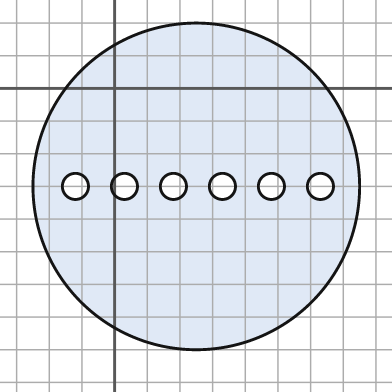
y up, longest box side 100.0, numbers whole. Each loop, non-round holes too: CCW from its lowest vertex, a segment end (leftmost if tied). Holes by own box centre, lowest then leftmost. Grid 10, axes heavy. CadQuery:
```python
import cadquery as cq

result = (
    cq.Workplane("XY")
    .moveTo(25.0, -30.0)
    .circle(50.0)
    .moveTo(-12.0, -30.0)
    .circle(4.0)
    .moveTo(3.0, -30.0)
    .circle(4.0)
    .moveTo(18.0, -30.0)
    .circle(4.0)
    .moveTo(33.0, -30.0)
    .circle(4.0)
    .moveTo(48.0, -30.0)
    .circle(4.0)
    .moveTo(63.0, -30.0)
    .circle(4.0)
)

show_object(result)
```